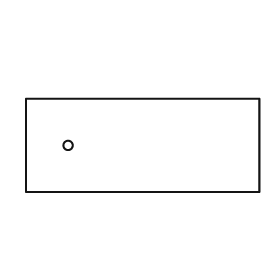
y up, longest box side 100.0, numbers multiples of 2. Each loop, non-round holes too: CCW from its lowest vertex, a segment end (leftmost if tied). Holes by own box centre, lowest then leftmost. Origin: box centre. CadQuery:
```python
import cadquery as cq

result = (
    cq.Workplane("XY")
    .moveTo(-50.0, -20.0)
    .lineTo(50.0, -20.0)
    .lineTo(50.0, 20.0)
    .lineTo(-50.0, 20.0)
    .close()
    .moveTo(-32.0, 0.0)
    .circle(2.0)
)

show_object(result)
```